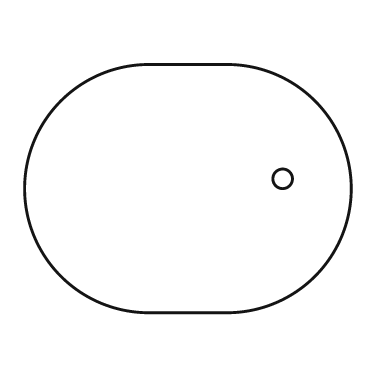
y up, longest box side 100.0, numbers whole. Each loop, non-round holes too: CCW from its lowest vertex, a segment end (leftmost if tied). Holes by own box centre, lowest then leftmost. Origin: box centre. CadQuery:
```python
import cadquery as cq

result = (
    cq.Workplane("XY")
    .moveTo(-12.0, -38.0)
    .lineTo(12.0, -38.0)
    .threePointArc((50.0, 0.0), (12.0, 38.0))
    .lineTo(-12.0, 38.0)
    .threePointArc((-50.0, 0.0), (-12.0, -38.0))
    .close()
    .moveTo(29.0, 3.0)
    .circle(3.0)
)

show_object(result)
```